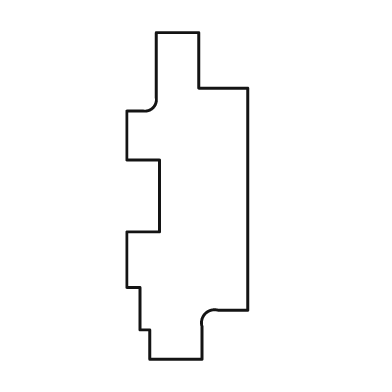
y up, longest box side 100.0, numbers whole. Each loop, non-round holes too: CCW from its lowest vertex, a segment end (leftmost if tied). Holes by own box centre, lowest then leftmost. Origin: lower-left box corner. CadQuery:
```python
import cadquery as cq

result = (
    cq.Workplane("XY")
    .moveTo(7.0, 0.0)
    .lineTo(23.0, 0.0)
    .lineTo(23.0, 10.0)
    .threePointArc((24.0, 14.0), (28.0, 15.0))
    .lineTo(37.0, 15.0)
    .lineTo(37.0, 83.0)
    .lineTo(22.0, 83.0)
    .lineTo(22.0, 100.0)
    .lineTo(9.0, 100.0)
    .lineTo(9.0, 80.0)
    .threePointArc((8.0, 77.0), (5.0, 76.0))
    .lineTo(0.0, 76.0)
    .lineTo(0.0, 61.0)
    .lineTo(10.0, 61.0)
    .lineTo(10.0, 39.0)
    .lineTo(0.0, 39.0)
    .lineTo(0.0, 22.0)
    .lineTo(4.0, 22.0)
    .lineTo(4.0, 9.0)
    .lineTo(7.0, 9.0)
    .close()
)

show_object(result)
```